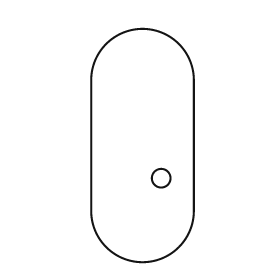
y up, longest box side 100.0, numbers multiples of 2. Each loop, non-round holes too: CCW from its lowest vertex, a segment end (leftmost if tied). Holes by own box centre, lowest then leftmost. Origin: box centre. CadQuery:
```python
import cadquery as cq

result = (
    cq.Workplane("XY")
    .moveTo(-22.0, -28.0)
    .threePointArc((0.0, -50.0), (22.0, -28.0))
    .lineTo(22.0, 28.0)
    .threePointArc((0.0, 50.0), (-22.0, 28.0))
    .close()
    .moveTo(8.0, -14.0)
    .circle(4.0)
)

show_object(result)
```